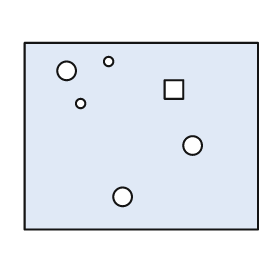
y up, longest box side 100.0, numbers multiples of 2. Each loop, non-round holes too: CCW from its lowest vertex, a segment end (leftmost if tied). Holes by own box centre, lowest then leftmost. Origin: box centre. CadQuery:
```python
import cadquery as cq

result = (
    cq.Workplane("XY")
    .moveTo(-50.0, -40.0)
    .lineTo(50.0, -40.0)
    .lineTo(50.0, 40.0)
    .lineTo(-50.0, 40.0)
    .close()
    .moveTo(-8.0, -26.0)
    .circle(4.0)
    .moveTo(22.0, -4.0)
    .circle(4.0)
    .moveTo(-26.0, 14.0)
    .circle(2.0)
    .moveTo(10.0, 16.0)
    .lineTo(18.0, 16.0)
    .lineTo(18.0, 24.0)
    .lineTo(10.0, 24.0)
    .close()
    .moveTo(-32.0, 28.0)
    .circle(4.0)
    .moveTo(-14.0, 32.0)
    .circle(2.0)
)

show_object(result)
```